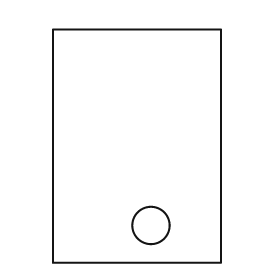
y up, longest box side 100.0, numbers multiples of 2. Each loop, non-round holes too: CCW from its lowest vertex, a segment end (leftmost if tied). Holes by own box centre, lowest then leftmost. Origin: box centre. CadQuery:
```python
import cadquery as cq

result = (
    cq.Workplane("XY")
    .moveTo(-36.0, -50.0)
    .lineTo(36.0, -50.0)
    .lineTo(36.0, 50.0)
    .lineTo(-36.0, 50.0)
    .close()
    .moveTo(6.0, -34.0)
    .circle(8.0)
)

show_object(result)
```